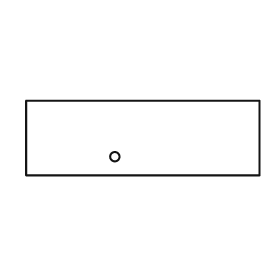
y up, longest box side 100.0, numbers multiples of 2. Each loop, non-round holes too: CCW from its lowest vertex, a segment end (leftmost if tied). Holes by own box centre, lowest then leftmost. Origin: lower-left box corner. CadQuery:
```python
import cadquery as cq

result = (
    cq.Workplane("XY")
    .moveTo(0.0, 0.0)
    .lineTo(100.0, 0.0)
    .lineTo(100.0, 32.0)
    .lineTo(0.0, 32.0)
    .close()
    .moveTo(38.0, 8.0)
    .circle(2.0)
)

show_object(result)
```